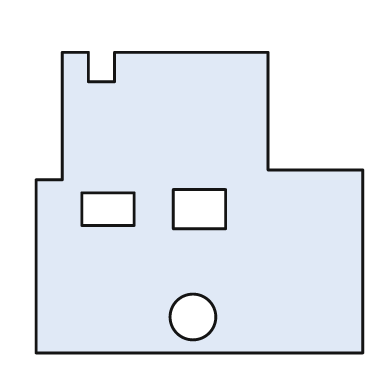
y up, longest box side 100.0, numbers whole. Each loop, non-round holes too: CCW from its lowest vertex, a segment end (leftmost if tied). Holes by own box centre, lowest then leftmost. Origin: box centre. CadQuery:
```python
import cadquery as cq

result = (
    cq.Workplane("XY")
    .moveTo(-50.0, -46.0)
    .lineTo(50.0, -46.0)
    .lineTo(50.0, 10.0)
    .lineTo(21.0, 10.0)
    .lineTo(21.0, 46.0)
    .lineTo(-26.0, 46.0)
    .lineTo(-26.0, 37.0)
    .lineTo(-34.0, 37.0)
    .lineTo(-34.0, 46.0)
    .lineTo(-42.0, 46.0)
    .lineTo(-42.0, 7.0)
    .lineTo(-50.0, 7.0)
    .close()
    .moveTo(-2.0, -35.0)
    .circle(7.0)
    .moveTo(-36.0, -7.0)
    .lineTo(-20.0, -7.0)
    .lineTo(-20.0, 3.0)
    .lineTo(-36.0, 3.0)
    .close()
    .moveTo(-8.0, -8.0)
    .lineTo(8.0, -8.0)
    .lineTo(8.0, 4.0)
    .lineTo(-8.0, 4.0)
    .close()
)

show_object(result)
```